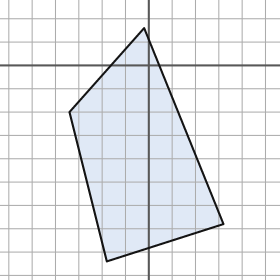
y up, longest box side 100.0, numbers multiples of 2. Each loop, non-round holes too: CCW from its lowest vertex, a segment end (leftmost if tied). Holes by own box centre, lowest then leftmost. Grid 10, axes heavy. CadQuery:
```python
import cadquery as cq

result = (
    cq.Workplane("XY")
    .moveTo(-18.0, -84.0)
    .lineTo(32.0, -68.0)
    .lineTo(-2.0, 16.0)
    .lineTo(-34.0, -20.0)
    .close()
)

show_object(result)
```